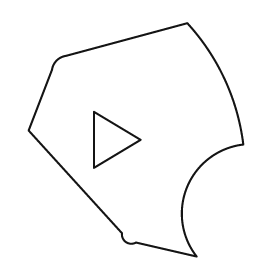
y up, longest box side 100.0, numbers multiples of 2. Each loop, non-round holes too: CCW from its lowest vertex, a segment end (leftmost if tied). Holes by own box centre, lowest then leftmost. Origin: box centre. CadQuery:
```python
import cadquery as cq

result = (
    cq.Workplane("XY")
    .moveTo(26.0, -50.0)
    .threePointArc((22.0, -20.0), (46.0, -2.0))
    .threePointArc((38.0, 26.0), (22.0, 50.0))
    .lineTo(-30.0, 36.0)
    .threePointArc((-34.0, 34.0), (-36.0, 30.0))
    .lineTo(-46.0, 4.0)
    .lineTo(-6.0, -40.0)
    .threePointArc((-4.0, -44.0), (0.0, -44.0))
    .close()
    .moveTo(-18.0, -12.0)
    .lineTo(2.0, 0.0)
    .lineTo(-18.0, 12.0)
    .close()
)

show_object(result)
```